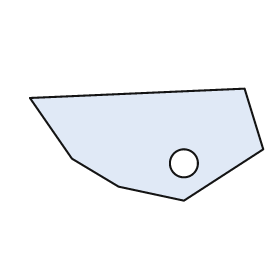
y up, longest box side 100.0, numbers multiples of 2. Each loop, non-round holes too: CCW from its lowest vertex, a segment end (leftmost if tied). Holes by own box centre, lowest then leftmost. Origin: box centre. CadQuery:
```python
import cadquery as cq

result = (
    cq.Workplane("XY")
    .moveTo(16.0, -24.0)
    .lineTo(50.0, -2.0)
    .lineTo(42.0, 24.0)
    .lineTo(-50.0, 20.0)
    .lineTo(-32.0, -6.0)
    .lineTo(-12.0, -18.0)
    .close()
    .moveTo(16.0, -8.0)
    .circle(6.0)
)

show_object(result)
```